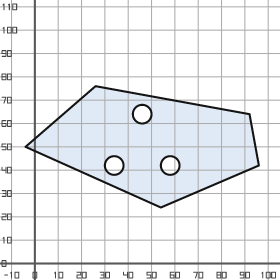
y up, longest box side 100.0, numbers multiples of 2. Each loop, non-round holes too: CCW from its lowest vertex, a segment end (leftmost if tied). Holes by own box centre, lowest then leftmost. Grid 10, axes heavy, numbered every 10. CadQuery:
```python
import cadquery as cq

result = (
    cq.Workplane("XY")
    .moveTo(54.0, 24.0)
    .lineTo(96.0, 42.0)
    .lineTo(92.0, 64.0)
    .lineTo(26.0, 76.0)
    .lineTo(-4.0, 50.0)
    .close()
    .moveTo(34.0, 42.0)
    .circle(4.0)
    .moveTo(58.0, 42.0)
    .circle(4.0)
    .moveTo(46.0, 64.0)
    .circle(4.0)
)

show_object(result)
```